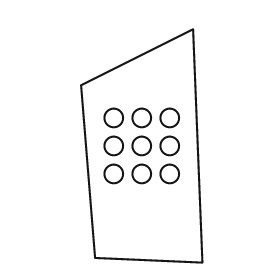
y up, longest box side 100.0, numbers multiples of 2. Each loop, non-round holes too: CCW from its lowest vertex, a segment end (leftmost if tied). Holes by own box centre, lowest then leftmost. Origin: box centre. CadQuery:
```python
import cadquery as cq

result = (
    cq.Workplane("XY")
    .moveTo(26.0, -50.0)
    .lineTo(22.0, 50.0)
    .lineTo(-26.0, 26.0)
    .lineTo(-20.0, -48.0)
    .close()
    .moveTo(-12.0, -12.0)
    .circle(4.0)
    .moveTo(0.0, -12.0)
    .circle(4.0)
    .moveTo(12.0, -12.0)
    .circle(4.0)
    .moveTo(-12.0, 0.0)
    .circle(4.0)
    .moveTo(0.0, 0.0)
    .circle(4.0)
    .moveTo(12.0, 0.0)
    .circle(4.0)
    .moveTo(-12.0, 12.0)
    .circle(4.0)
    .moveTo(0.0, 12.0)
    .circle(4.0)
    .moveTo(12.0, 12.0)
    .circle(4.0)
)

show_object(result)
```